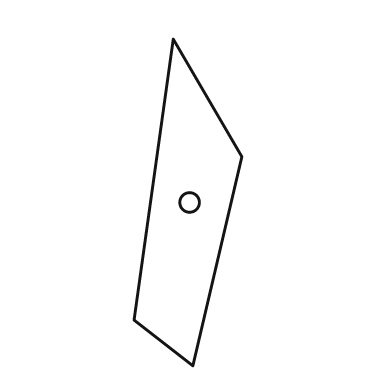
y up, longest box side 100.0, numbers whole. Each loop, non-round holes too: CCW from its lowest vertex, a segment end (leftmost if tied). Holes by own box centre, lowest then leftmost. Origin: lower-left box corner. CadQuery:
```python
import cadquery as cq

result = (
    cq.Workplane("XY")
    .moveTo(18.0, 0.0)
    .lineTo(33.0, 64.0)
    .lineTo(12.0, 100.0)
    .lineTo(0.0, 14.0)
    .close()
    .moveTo(17.0, 50.0)
    .circle(3.0)
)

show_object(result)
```